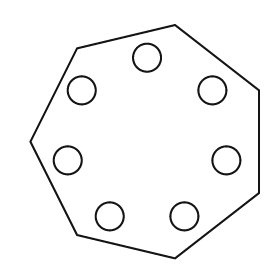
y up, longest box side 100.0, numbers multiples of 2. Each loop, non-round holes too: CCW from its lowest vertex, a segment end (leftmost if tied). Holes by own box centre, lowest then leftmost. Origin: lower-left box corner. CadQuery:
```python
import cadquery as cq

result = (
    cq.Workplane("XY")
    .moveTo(62.0, 0.0)
    .lineTo(98.0, 28.0)
    .lineTo(98.0, 72.0)
    .lineTo(62.0, 100.0)
    .lineTo(20.0, 90.0)
    .lineTo(0.0, 50.0)
    .lineTo(20.0, 10.0)
    .close()
    .moveTo(34.0, 18.0)
    .circle(6.0)
    .moveTo(66.0, 18.0)
    .circle(6.0)
    .moveTo(16.0, 42.0)
    .circle(6.0)
    .moveTo(84.0, 42.0)
    .circle(6.0)
    .moveTo(22.0, 72.0)
    .circle(6.0)
    .moveTo(78.0, 72.0)
    .circle(6.0)
    .moveTo(50.0, 86.0)
    .circle(6.0)
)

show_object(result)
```